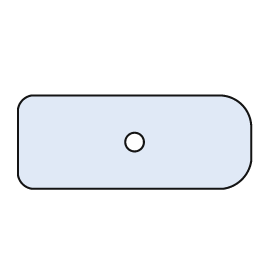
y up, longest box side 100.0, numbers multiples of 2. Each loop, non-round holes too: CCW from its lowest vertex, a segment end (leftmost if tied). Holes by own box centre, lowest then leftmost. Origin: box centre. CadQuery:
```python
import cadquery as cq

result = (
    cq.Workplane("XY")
    .moveTo(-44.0, -20.0)
    .lineTo(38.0, -20.0)
    .threePointArc((46.0, -16.0), (50.0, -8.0))
    .lineTo(50.0, 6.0)
    .threePointArc((46.0, 16.0), (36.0, 20.0))
    .lineTo(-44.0, 20.0)
    .threePointArc((-48.0, 18.0), (-50.0, 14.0))
    .lineTo(-50.0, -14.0)
    .threePointArc((-48.0, -18.0), (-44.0, -20.0))
    .close()
    .moveTo(0.0, 0.0)
    .circle(4.0)
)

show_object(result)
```